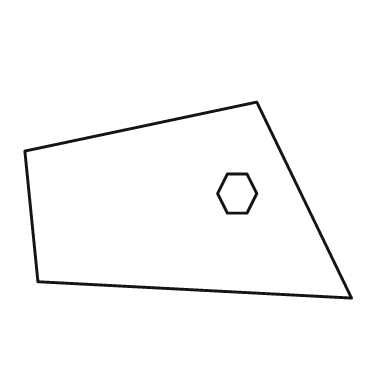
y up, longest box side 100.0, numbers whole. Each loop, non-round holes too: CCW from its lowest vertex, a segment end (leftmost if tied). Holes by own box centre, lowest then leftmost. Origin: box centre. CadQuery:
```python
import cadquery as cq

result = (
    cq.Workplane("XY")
    .moveTo(50.0, -30.0)
    .lineTo(21.0, 30.0)
    .lineTo(-50.0, 15.0)
    .lineTo(-46.0, -25.0)
    .close()
    .moveTo(12.0, -4.0)
    .lineTo(18.0, -4.0)
    .lineTo(21.0, 2.0)
    .lineTo(18.0, 8.0)
    .lineTo(12.0, 8.0)
    .lineTo(9.0, 2.0)
    .close()
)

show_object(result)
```